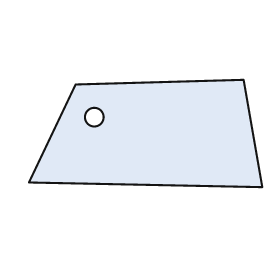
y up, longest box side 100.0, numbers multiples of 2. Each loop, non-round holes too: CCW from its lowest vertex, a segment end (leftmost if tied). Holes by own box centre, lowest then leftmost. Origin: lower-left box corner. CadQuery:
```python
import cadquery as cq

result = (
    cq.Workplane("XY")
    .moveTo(100.0, 0.0)
    .lineTo(92.0, 46.0)
    .lineTo(20.0, 44.0)
    .lineTo(0.0, 2.0)
    .close()
    .moveTo(28.0, 30.0)
    .circle(4.0)
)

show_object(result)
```